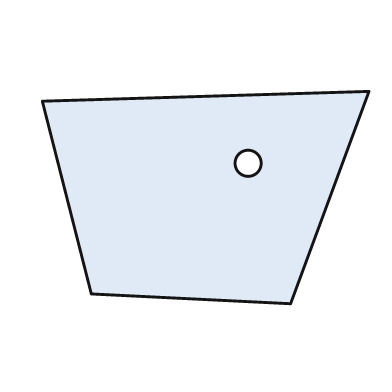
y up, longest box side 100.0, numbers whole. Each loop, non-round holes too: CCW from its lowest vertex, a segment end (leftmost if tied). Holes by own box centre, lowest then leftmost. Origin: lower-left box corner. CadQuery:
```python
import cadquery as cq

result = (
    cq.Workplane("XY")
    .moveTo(76.0, 0.0)
    .lineTo(100.0, 65.0)
    .lineTo(0.0, 62.0)
    .lineTo(15.0, 3.0)
    .close()
    .moveTo(63.0, 43.0)
    .circle(4.0)
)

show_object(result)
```